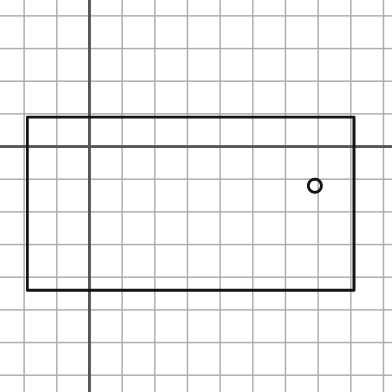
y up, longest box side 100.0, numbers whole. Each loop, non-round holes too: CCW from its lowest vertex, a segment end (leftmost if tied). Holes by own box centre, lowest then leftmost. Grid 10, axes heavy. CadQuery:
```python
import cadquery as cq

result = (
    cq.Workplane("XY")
    .moveTo(-19.0, -44.0)
    .lineTo(81.0, -44.0)
    .lineTo(81.0, 9.0)
    .lineTo(-19.0, 9.0)
    .close()
    .moveTo(69.0, -12.0)
    .circle(2.0)
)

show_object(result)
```